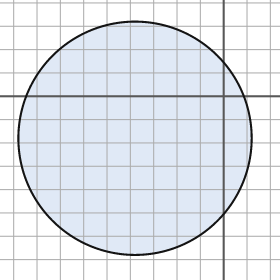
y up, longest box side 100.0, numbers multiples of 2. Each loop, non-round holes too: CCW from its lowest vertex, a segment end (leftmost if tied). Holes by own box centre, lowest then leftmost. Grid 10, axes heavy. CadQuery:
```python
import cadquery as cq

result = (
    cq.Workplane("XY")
    .moveTo(-38.0, -18.0)
    .circle(50.0)
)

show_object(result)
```